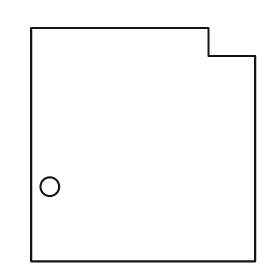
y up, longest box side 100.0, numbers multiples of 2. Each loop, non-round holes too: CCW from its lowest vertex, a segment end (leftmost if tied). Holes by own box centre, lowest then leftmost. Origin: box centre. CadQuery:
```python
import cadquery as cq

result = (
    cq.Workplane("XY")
    .moveTo(-48.0, -50.0)
    .lineTo(48.0, -50.0)
    .lineTo(48.0, 38.0)
    .lineTo(28.0, 38.0)
    .lineTo(28.0, 50.0)
    .lineTo(-48.0, 50.0)
    .close()
    .moveTo(-40.0, -18.0)
    .circle(4.0)
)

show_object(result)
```